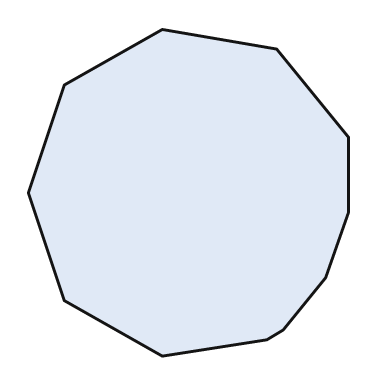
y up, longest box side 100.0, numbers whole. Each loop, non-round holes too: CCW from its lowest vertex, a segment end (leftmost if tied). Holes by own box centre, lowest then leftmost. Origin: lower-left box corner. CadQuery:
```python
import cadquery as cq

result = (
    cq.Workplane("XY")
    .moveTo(41.0, 0.0)
    .lineTo(73.0, 5.0)
    .lineTo(78.0, 8.0)
    .lineTo(91.0, 24.0)
    .lineTo(98.0, 44.0)
    .lineTo(98.0, 67.0)
    .lineTo(76.0, 94.0)
    .lineTo(41.0, 100.0)
    .lineTo(11.0, 83.0)
    .lineTo(0.0, 50.0)
    .lineTo(11.0, 17.0)
    .close()
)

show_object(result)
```